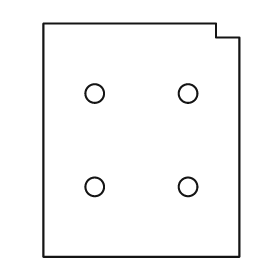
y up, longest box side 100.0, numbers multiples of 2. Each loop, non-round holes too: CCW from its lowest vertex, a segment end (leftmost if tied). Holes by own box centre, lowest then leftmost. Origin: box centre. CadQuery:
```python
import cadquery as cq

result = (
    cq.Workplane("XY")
    .moveTo(-42.0, -50.0)
    .lineTo(42.0, -50.0)
    .lineTo(42.0, 44.0)
    .lineTo(32.0, 44.0)
    .lineTo(32.0, 50.0)
    .lineTo(-42.0, 50.0)
    .close()
    .moveTo(-20.0, -20.0)
    .circle(4.0)
    .moveTo(20.0, -20.0)
    .circle(4.0)
    .moveTo(-20.0, 20.0)
    .circle(4.0)
    .moveTo(20.0, 20.0)
    .circle(4.0)
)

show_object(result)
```